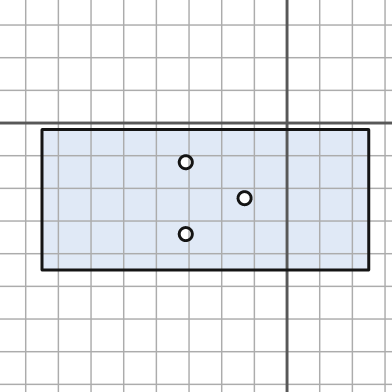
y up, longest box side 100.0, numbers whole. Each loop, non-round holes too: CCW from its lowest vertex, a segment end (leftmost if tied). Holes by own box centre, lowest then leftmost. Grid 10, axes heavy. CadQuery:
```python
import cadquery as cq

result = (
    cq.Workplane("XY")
    .moveTo(-75.0, -45.0)
    .lineTo(25.0, -45.0)
    .lineTo(25.0, -2.0)
    .lineTo(-75.0, -2.0)
    .close()
    .moveTo(-31.0, -34.0)
    .circle(2.0)
    .moveTo(-13.0, -23.0)
    .circle(2.0)
    .moveTo(-31.0, -12.0)
    .circle(2.0)
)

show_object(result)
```